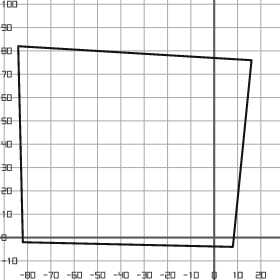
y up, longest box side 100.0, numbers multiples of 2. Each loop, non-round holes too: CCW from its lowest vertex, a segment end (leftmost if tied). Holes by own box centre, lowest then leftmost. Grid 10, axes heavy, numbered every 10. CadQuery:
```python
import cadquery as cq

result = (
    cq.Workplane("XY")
    .moveTo(8.0, -4.0)
    .lineTo(16.0, 76.0)
    .lineTo(-84.0, 82.0)
    .lineTo(-82.0, -2.0)
    .close()
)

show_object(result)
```